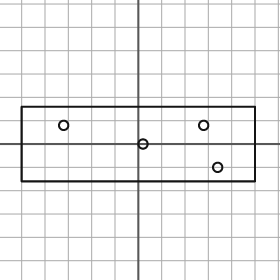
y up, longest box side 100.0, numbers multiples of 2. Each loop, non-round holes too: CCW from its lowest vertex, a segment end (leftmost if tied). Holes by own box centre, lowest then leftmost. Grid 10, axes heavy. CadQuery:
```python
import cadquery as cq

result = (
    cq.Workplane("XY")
    .moveTo(-50.0, -16.0)
    .lineTo(50.0, -16.0)
    .lineTo(50.0, 16.0)
    .lineTo(-50.0, 16.0)
    .close()
    .moveTo(34.0, -10.0)
    .circle(2.0)
    .moveTo(2.0, 0.0)
    .circle(2.0)
    .moveTo(-32.0, 8.0)
    .circle(2.0)
    .moveTo(28.0, 8.0)
    .circle(2.0)
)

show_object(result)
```